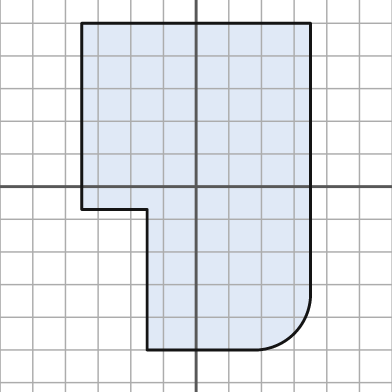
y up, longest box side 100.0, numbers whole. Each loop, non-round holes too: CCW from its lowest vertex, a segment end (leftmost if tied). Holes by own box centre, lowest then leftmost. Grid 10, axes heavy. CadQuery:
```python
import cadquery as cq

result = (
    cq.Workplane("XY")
    .moveTo(-15.0, -50.0)
    .lineTo(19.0, -50.0)
    .threePointArc((30.0, -45.0), (35.0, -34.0))
    .lineTo(35.0, 50.0)
    .lineTo(-35.0, 50.0)
    .lineTo(-35.0, -7.0)
    .lineTo(-15.0, -7.0)
    .close()
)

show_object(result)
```